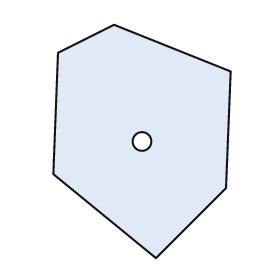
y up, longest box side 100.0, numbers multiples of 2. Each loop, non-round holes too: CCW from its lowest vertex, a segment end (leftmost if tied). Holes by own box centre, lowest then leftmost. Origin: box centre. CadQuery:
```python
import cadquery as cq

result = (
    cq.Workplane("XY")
    .moveTo(6.0, -50.0)
    .lineTo(36.0, -20.0)
    .lineTo(38.0, 30.0)
    .lineTo(-12.0, 50.0)
    .lineTo(-36.0, 38.0)
    .lineTo(-38.0, -14.0)
    .close()
    .moveTo(0.0, 0.0)
    .circle(4.0)
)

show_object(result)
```